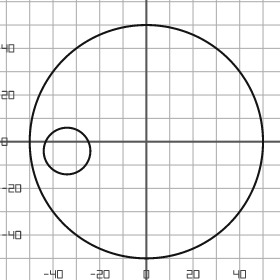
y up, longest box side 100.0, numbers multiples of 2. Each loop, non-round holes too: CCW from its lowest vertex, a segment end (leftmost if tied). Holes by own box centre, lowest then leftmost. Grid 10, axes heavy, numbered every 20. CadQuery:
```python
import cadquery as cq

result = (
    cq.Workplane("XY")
    .moveTo(0.0, 0.0)
    .circle(50.0)
    .moveTo(-34.0, -4.0)
    .circle(10.0)
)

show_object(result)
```